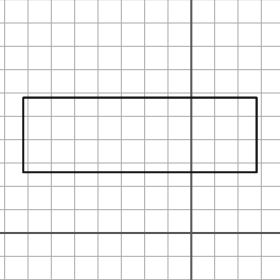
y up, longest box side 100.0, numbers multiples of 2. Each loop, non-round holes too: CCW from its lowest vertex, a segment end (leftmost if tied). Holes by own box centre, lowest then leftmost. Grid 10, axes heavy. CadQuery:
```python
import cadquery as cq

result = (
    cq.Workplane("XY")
    .moveTo(-72.0, 26.0)
    .lineTo(28.0, 26.0)
    .lineTo(28.0, 58.0)
    .lineTo(-72.0, 58.0)
    .close()
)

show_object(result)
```